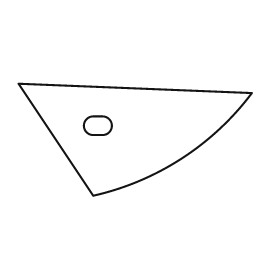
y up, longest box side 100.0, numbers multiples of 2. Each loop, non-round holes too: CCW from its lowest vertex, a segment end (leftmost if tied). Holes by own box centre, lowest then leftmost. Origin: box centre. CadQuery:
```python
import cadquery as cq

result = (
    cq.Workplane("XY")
    .moveTo(-18.0, -24.0)
    .threePointArc((20.0, -8.0), (50.0, 20.0))
    .lineTo(-50.0, 24.0)
    .close()
    .moveTo(-18.0, 2.0)
    .lineTo(-14.0, 2.0)
    .threePointArc((-10.0, 6.0), (-14.0, 10.0))
    .lineTo(-18.0, 10.0)
    .threePointArc((-22.0, 6.0), (-18.0, 2.0))
    .close()
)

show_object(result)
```